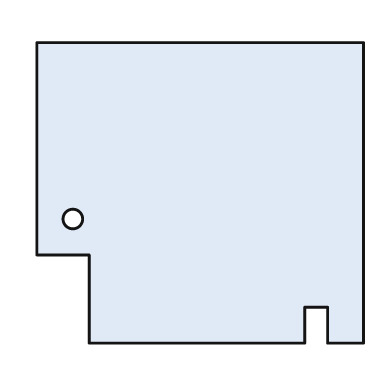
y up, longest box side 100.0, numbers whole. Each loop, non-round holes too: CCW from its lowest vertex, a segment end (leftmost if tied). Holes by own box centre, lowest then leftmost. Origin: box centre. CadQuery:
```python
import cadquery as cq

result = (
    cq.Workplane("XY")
    .moveTo(-34.0, -46.0)
    .lineTo(32.0, -46.0)
    .lineTo(32.0, -35.0)
    .lineTo(39.0, -35.0)
    .lineTo(39.0, -46.0)
    .lineTo(50.0, -46.0)
    .lineTo(50.0, 46.0)
    .lineTo(-50.0, 46.0)
    .lineTo(-50.0, -19.0)
    .lineTo(-34.0, -19.0)
    .close()
    .moveTo(-39.0, -8.0)
    .circle(3.0)
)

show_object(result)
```